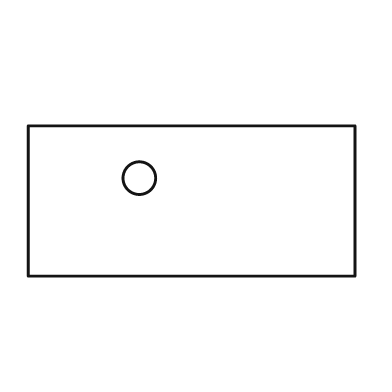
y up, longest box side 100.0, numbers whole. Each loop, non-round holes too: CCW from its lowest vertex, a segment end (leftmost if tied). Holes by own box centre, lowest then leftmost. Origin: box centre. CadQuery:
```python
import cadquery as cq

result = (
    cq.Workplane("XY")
    .moveTo(-50.0, -23.0)
    .lineTo(50.0, -23.0)
    .lineTo(50.0, 23.0)
    .lineTo(-50.0, 23.0)
    .close()
    .moveTo(-16.0, 7.0)
    .circle(5.0)
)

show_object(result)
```